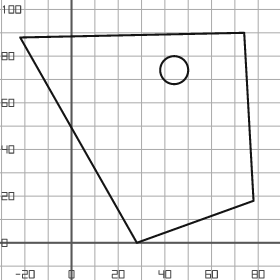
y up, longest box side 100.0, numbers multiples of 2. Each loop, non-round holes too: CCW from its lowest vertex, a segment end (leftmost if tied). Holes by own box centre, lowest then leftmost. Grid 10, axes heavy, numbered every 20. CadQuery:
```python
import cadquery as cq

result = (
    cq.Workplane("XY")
    .moveTo(28.0, 0.0)
    .lineTo(78.0, 18.0)
    .lineTo(74.0, 90.0)
    .lineTo(-22.0, 88.0)
    .close()
    .moveTo(44.0, 74.0)
    .circle(6.0)
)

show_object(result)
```